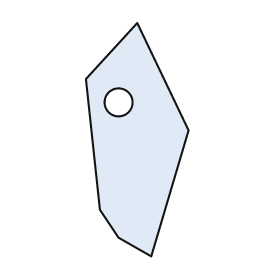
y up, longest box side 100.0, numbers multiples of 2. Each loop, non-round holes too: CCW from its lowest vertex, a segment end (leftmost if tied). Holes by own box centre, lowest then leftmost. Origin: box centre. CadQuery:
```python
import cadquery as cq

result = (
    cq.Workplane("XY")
    .moveTo(6.0, -50.0)
    .lineTo(22.0, 4.0)
    .lineTo(0.0, 50.0)
    .lineTo(-22.0, 26.0)
    .lineTo(-16.0, -30.0)
    .lineTo(-8.0, -42.0)
    .close()
    .moveTo(-8.0, 16.0)
    .circle(6.0)
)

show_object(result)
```